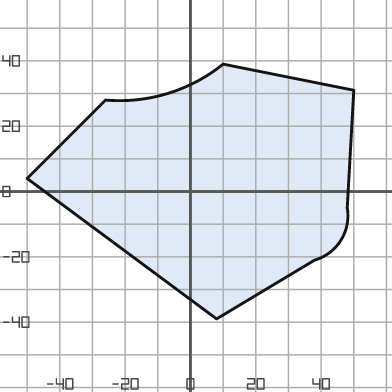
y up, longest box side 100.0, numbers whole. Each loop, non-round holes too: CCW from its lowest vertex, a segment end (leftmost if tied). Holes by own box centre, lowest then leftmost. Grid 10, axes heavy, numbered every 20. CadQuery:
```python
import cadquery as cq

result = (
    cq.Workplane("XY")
    .moveTo(8.0, -39.0)
    .lineTo(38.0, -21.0)
    .threePointArc((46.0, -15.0), (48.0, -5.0))
    .lineTo(50.0, 31.0)
    .lineTo(10.0, 39.0)
    .threePointArc((-7.0, 30.0), (-26.0, 28.0))
    .lineTo(-50.0, 4.0)
    .close()
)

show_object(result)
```